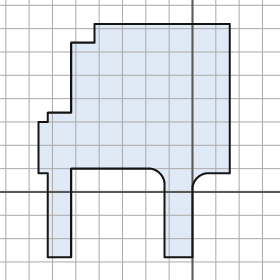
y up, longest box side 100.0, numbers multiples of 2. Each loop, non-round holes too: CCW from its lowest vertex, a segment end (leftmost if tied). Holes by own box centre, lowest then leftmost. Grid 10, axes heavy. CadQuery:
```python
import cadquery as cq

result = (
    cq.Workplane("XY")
    .moveTo(-62.0, -28.0)
    .lineTo(-52.0, -28.0)
    .lineTo(-52.0, 10.0)
    .lineTo(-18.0, 10.0)
    .threePointArc((-14.0, 8.0), (-12.0, 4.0))
    .lineTo(-12.0, -28.0)
    .lineTo(0.0, -28.0)
    .lineTo(0.0, 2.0)
    .threePointArc((2.0, 6.0), (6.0, 8.0))
    .lineTo(16.0, 8.0)
    .lineTo(16.0, 72.0)
    .lineTo(-42.0, 72.0)
    .lineTo(-42.0, 64.0)
    .lineTo(-52.0, 64.0)
    .lineTo(-52.0, 34.0)
    .lineTo(-62.0, 34.0)
    .lineTo(-62.0, 30.0)
    .lineTo(-66.0, 30.0)
    .lineTo(-66.0, 8.0)
    .lineTo(-62.0, 8.0)
    .close()
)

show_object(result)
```